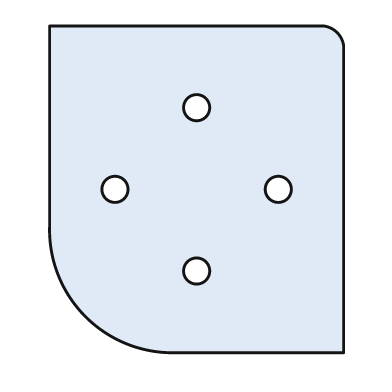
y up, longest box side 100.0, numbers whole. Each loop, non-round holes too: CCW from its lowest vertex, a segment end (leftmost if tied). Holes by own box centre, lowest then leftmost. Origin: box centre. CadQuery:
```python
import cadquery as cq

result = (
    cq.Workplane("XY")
    .moveTo(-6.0, -50.0)
    .lineTo(45.0, -50.0)
    .lineTo(45.0, 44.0)
    .threePointArc((43.0, 48.0), (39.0, 50.0))
    .lineTo(-45.0, 50.0)
    .lineTo(-45.0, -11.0)
    .threePointArc((-34.0, -39.0), (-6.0, -50.0))
    .close()
    .moveTo(0.0, -25.0)
    .circle(4.0)
    .moveTo(-25.0, 0.0)
    .circle(4.0)
    .moveTo(25.0, 0.0)
    .circle(4.0)
    .moveTo(0.0, 25.0)
    .circle(4.0)
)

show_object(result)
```